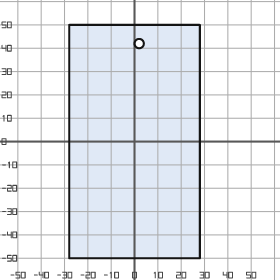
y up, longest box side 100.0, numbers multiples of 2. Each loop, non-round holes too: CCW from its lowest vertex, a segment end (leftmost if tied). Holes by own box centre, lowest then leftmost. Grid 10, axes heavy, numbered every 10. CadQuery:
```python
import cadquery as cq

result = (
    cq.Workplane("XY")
    .moveTo(-28.0, -50.0)
    .lineTo(28.0, -50.0)
    .lineTo(28.0, 50.0)
    .lineTo(-28.0, 50.0)
    .close()
    .moveTo(2.0, 42.0)
    .circle(2.0)
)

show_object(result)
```